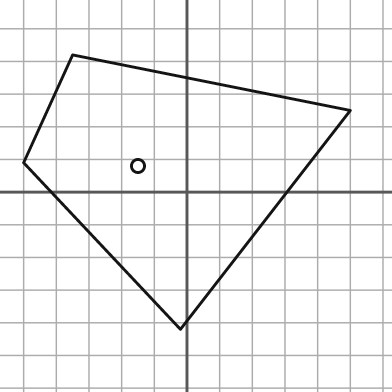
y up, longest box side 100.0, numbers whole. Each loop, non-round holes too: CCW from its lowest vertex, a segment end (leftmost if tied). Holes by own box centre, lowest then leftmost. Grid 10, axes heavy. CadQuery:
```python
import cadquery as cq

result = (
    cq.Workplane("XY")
    .moveTo(-2.0, -42.0)
    .lineTo(50.0, 25.0)
    .lineTo(-35.0, 42.0)
    .lineTo(-50.0, 9.0)
    .close()
    .moveTo(-15.0, 8.0)
    .circle(2.0)
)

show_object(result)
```